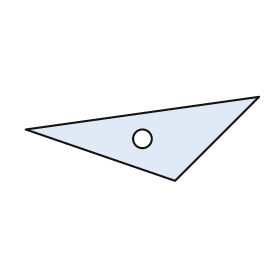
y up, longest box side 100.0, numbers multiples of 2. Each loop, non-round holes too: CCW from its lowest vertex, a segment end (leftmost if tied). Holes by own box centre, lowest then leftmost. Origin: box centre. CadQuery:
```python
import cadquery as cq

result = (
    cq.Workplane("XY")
    .moveTo(14.0, -18.0)
    .lineTo(50.0, 18.0)
    .lineTo(-50.0, 4.0)
    .close()
    .moveTo(0.0, 0.0)
    .circle(4.0)
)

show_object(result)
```